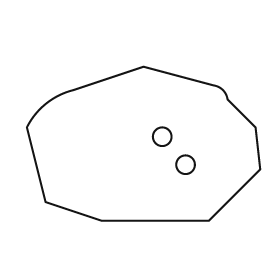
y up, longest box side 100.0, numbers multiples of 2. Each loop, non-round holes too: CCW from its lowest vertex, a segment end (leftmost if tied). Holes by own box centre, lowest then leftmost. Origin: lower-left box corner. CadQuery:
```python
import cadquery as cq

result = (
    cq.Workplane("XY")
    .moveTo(32.0, 0.0)
    .lineTo(78.0, 0.0)
    .lineTo(100.0, 22.0)
    .lineTo(98.0, 40.0)
    .lineTo(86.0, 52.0)
    .threePointArc((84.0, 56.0), (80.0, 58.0))
    .lineTo(50.0, 66.0)
    .lineTo(20.0, 56.0)
    .threePointArc((8.0, 50.0), (0.0, 40.0))
    .lineTo(8.0, 8.0)
    .close()
    .moveTo(68.0, 24.0)
    .circle(4.0)
    .moveTo(58.0, 36.0)
    .circle(4.0)
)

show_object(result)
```